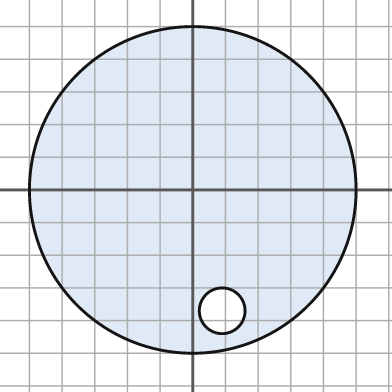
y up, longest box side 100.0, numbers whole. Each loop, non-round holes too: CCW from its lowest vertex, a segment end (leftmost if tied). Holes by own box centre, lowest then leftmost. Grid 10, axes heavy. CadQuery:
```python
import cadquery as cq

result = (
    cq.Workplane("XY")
    .moveTo(0.0, 0.0)
    .circle(50.0)
    .moveTo(9.0, -37.0)
    .circle(7.0)
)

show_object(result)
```